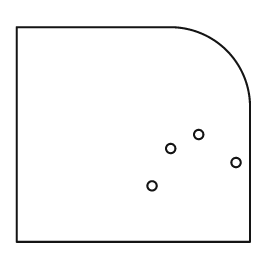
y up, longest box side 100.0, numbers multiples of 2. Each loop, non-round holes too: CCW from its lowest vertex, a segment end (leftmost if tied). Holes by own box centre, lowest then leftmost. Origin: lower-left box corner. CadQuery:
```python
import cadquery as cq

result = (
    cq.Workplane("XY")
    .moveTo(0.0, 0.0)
    .lineTo(100.0, 0.0)
    .lineTo(100.0, 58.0)
    .threePointArc((90.0, 82.0), (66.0, 92.0))
    .lineTo(0.0, 92.0)
    .close()
    .moveTo(58.0, 24.0)
    .circle(2.0)
    .moveTo(94.0, 34.0)
    .circle(2.0)
    .moveTo(66.0, 40.0)
    .circle(2.0)
    .moveTo(78.0, 46.0)
    .circle(2.0)
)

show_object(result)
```